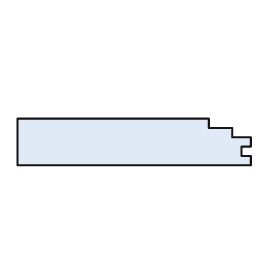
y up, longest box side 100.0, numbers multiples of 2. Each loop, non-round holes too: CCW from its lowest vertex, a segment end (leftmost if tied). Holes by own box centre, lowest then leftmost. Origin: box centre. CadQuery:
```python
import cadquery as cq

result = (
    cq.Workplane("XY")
    .moveTo(-50.0, -10.0)
    .lineTo(50.0, -10.0)
    .lineTo(50.0, -6.0)
    .lineTo(46.0, -6.0)
    .lineTo(46.0, -2.0)
    .lineTo(50.0, -2.0)
    .lineTo(50.0, 2.0)
    .lineTo(42.0, 2.0)
    .lineTo(42.0, 6.0)
    .lineTo(32.0, 6.0)
    .lineTo(32.0, 10.0)
    .lineTo(-50.0, 10.0)
    .close()
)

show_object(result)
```